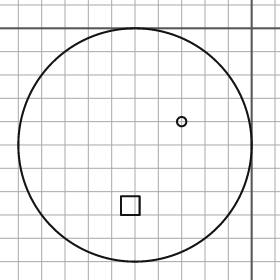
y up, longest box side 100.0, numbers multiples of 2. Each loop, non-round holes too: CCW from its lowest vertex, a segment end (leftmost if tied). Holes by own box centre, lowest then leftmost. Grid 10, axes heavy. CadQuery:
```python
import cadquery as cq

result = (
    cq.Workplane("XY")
    .moveTo(-50.0, -50.0)
    .circle(50.0)
    .moveTo(-56.0, -80.0)
    .lineTo(-48.0, -80.0)
    .lineTo(-48.0, -72.0)
    .lineTo(-56.0, -72.0)
    .close()
    .moveTo(-30.0, -40.0)
    .circle(2.0)
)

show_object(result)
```